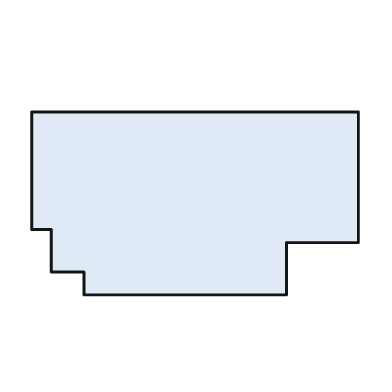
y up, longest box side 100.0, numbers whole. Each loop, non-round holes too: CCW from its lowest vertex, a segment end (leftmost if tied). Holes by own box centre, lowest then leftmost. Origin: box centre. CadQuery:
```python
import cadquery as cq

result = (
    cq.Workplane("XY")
    .moveTo(-34.0, -28.0)
    .lineTo(28.0, -28.0)
    .lineTo(28.0, -12.0)
    .lineTo(50.0, -12.0)
    .lineTo(50.0, 28.0)
    .lineTo(-50.0, 28.0)
    .lineTo(-50.0, -8.0)
    .lineTo(-44.0, -8.0)
    .lineTo(-44.0, -21.0)
    .lineTo(-34.0, -21.0)
    .close()
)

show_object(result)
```